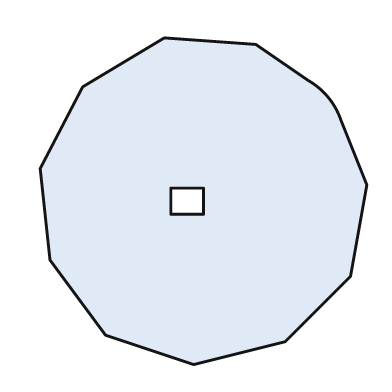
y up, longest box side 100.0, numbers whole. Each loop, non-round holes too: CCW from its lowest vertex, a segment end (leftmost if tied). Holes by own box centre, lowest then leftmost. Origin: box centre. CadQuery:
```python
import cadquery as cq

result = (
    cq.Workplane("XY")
    .moveTo(-3.0, -50.0)
    .lineTo(25.0, -43.0)
    .lineTo(45.0, -23.0)
    .lineTo(50.0, 5.0)
    .lineTo(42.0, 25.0)
    .threePointArc((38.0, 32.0), (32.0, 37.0))
    .lineTo(16.0, 48.0)
    .lineTo(-12.0, 50.0)
    .lineTo(-37.0, 35.0)
    .lineTo(-50.0, 10.0)
    .lineTo(-47.0, -18.0)
    .lineTo(-30.0, -41.0)
    .close()
    .moveTo(-10.0, -4.0)
    .lineTo(0.0, -4.0)
    .lineTo(0.0, 4.0)
    .lineTo(-10.0, 4.0)
    .close()
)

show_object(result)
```